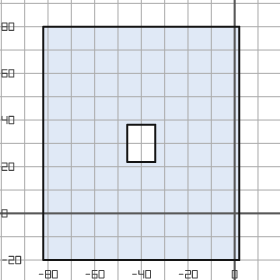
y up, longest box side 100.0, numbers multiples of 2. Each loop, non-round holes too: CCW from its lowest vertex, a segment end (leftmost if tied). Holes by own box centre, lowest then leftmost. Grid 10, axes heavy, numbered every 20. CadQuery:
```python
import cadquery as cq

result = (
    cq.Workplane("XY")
    .moveTo(-82.0, -20.0)
    .lineTo(2.0, -20.0)
    .lineTo(2.0, 80.0)
    .lineTo(-82.0, 80.0)
    .close()
    .moveTo(-46.0, 22.0)
    .lineTo(-34.0, 22.0)
    .lineTo(-34.0, 38.0)
    .lineTo(-46.0, 38.0)
    .close()
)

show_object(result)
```